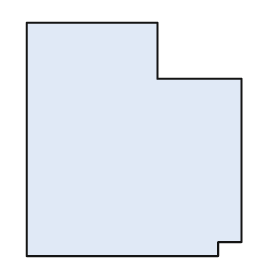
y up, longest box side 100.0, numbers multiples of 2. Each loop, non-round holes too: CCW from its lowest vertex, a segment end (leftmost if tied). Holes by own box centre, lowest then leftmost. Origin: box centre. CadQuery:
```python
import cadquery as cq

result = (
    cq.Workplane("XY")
    .moveTo(-46.0, -50.0)
    .lineTo(36.0, -50.0)
    .lineTo(36.0, -44.0)
    .lineTo(46.0, -44.0)
    .lineTo(46.0, 26.0)
    .lineTo(10.0, 26.0)
    .lineTo(10.0, 50.0)
    .lineTo(-46.0, 50.0)
    .close()
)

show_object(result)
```